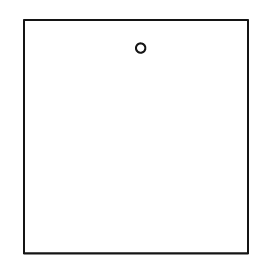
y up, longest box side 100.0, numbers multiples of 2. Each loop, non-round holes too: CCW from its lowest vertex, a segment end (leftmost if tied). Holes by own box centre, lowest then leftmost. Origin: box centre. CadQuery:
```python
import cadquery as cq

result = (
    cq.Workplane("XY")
    .moveTo(-48.0, -50.0)
    .lineTo(48.0, -50.0)
    .lineTo(48.0, 50.0)
    .lineTo(-48.0, 50.0)
    .close()
    .moveTo(2.0, 38.0)
    .circle(2.0)
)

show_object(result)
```